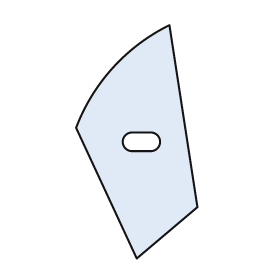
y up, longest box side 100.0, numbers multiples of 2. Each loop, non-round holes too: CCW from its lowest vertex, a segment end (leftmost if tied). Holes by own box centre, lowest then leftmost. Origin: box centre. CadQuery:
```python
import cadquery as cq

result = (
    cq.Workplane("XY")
    .moveTo(0.0, -50.0)
    .lineTo(26.0, -28.0)
    .lineTo(14.0, 50.0)
    .threePointArc((-10.0, 32.0), (-26.0, 6.0))
    .close()
    .moveTo(-2.0, -4.0)
    .lineTo(6.0, -4.0)
    .threePointArc((10.0, 0.0), (6.0, 4.0))
    .lineTo(-2.0, 4.0)
    .threePointArc((-6.0, 0.0), (-2.0, -4.0))
    .close()
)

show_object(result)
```